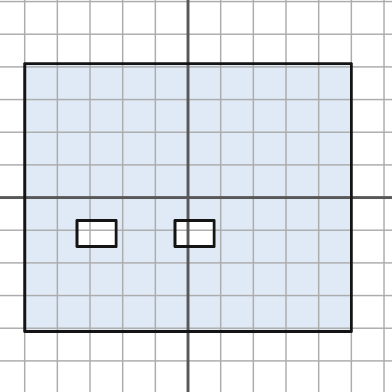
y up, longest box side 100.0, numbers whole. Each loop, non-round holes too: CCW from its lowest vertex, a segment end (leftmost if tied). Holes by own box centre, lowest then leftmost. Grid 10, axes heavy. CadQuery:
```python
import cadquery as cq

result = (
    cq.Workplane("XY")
    .moveTo(-50.0, -41.0)
    .lineTo(50.0, -41.0)
    .lineTo(50.0, 41.0)
    .lineTo(-50.0, 41.0)
    .close()
    .moveTo(-34.0, -15.0)
    .lineTo(-22.0, -15.0)
    .lineTo(-22.0, -7.0)
    .lineTo(-34.0, -7.0)
    .close()
    .moveTo(-4.0, -15.0)
    .lineTo(8.0, -15.0)
    .lineTo(8.0, -7.0)
    .lineTo(-4.0, -7.0)
    .close()
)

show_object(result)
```